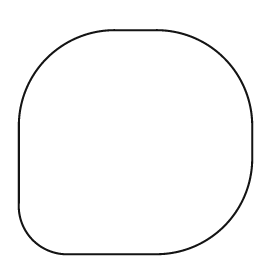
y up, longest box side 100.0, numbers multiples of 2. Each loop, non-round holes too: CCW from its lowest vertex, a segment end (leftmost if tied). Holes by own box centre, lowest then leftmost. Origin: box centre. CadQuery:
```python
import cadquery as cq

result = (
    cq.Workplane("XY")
    .moveTo(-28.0, -48.0)
    .lineTo(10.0, -48.0)
    .threePointArc((38.0, -36.0), (50.0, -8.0))
    .lineTo(50.0, 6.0)
    .threePointArc((38.0, 36.0), (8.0, 48.0))
    .lineTo(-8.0, 48.0)
    .threePointArc((-38.0, 36.0), (-50.0, 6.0))
    .lineTo(-50.0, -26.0)
    .threePointArc((-44.0, -42.0), (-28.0, -48.0))
    .close()
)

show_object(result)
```